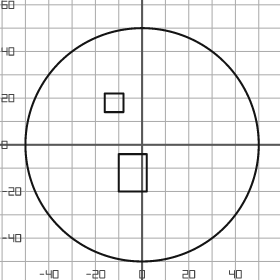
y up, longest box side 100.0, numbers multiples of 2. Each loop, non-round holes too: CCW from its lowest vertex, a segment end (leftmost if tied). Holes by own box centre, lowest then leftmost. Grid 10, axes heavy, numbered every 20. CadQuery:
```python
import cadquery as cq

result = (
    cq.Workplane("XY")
    .moveTo(0.0, 0.0)
    .circle(50.0)
    .moveTo(-10.0, -20.0)
    .lineTo(2.0, -20.0)
    .lineTo(2.0, -4.0)
    .lineTo(-10.0, -4.0)
    .close()
    .moveTo(-16.0, 14.0)
    .lineTo(-8.0, 14.0)
    .lineTo(-8.0, 22.0)
    .lineTo(-16.0, 22.0)
    .close()
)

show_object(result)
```